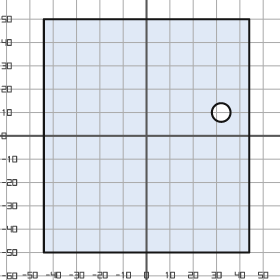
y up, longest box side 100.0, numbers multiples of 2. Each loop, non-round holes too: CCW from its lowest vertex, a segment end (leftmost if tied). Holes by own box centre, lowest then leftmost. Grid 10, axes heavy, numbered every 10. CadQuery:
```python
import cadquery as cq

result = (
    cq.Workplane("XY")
    .moveTo(-44.0, -50.0)
    .lineTo(44.0, -50.0)
    .lineTo(44.0, 50.0)
    .lineTo(-44.0, 50.0)
    .close()
    .moveTo(32.0, 10.0)
    .circle(4.0)
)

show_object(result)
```